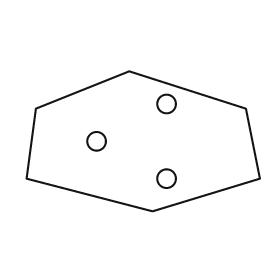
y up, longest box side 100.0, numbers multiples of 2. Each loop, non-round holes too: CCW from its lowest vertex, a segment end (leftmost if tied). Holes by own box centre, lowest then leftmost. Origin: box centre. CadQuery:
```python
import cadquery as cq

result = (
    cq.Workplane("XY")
    .moveTo(4.0, -30.0)
    .lineTo(50.0, -16.0)
    .lineTo(44.0, 14.0)
    .lineTo(-6.0, 30.0)
    .lineTo(-46.0, 14.0)
    .lineTo(-50.0, -16.0)
    .close()
    .moveTo(10.0, -16.0)
    .circle(4.0)
    .moveTo(-20.0, 0.0)
    .circle(4.0)
    .moveTo(10.0, 16.0)
    .circle(4.0)
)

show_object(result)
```